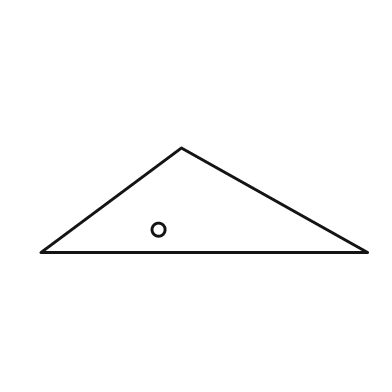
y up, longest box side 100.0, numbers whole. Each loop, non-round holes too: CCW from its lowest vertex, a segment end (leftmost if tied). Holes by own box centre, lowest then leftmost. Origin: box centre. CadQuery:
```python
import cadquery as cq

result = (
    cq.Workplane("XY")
    .moveTo(-50.0, -16.0)
    .lineTo(50.0, -16.0)
    .lineTo(-7.0, 16.0)
    .close()
    .moveTo(-14.0, -9.0)
    .circle(2.0)
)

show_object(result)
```